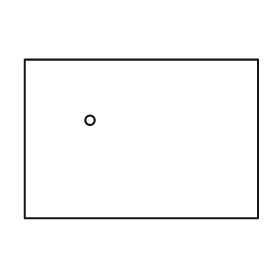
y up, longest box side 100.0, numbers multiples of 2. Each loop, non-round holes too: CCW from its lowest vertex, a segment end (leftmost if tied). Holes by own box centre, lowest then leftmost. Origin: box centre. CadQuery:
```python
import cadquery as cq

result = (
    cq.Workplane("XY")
    .moveTo(-50.0, -34.0)
    .lineTo(50.0, -34.0)
    .lineTo(50.0, 34.0)
    .lineTo(-50.0, 34.0)
    .close()
    .moveTo(-22.0, 8.0)
    .circle(2.0)
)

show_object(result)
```